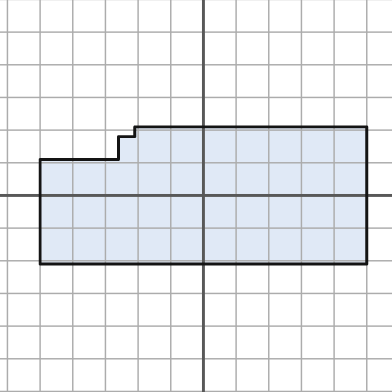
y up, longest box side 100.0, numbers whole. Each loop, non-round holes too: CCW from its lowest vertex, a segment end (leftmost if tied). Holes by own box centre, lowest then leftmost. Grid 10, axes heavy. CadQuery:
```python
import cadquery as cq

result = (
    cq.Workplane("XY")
    .moveTo(-50.0, -21.0)
    .lineTo(50.0, -21.0)
    .lineTo(50.0, 21.0)
    .lineTo(-21.0, 21.0)
    .lineTo(-21.0, 18.0)
    .lineTo(-26.0, 18.0)
    .lineTo(-26.0, 11.0)
    .lineTo(-50.0, 11.0)
    .close()
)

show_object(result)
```